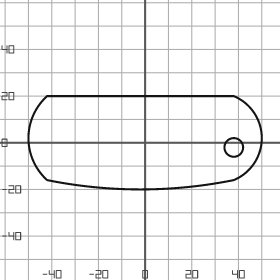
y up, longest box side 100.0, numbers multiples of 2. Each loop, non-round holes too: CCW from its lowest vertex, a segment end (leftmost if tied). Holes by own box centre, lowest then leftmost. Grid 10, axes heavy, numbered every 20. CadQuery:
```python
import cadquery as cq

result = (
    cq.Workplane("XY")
    .moveTo(-42.0, -16.0)
    .threePointArc((-2.0, -20.0), (38.0, -16.0))
    .threePointArc((50.0, 2.0), (38.0, 20.0))
    .lineTo(-42.0, 20.0)
    .threePointArc((-50.0, 2.0), (-42.0, -16.0))
    .close()
    .moveTo(38.0, -2.0)
    .circle(4.0)
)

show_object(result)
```